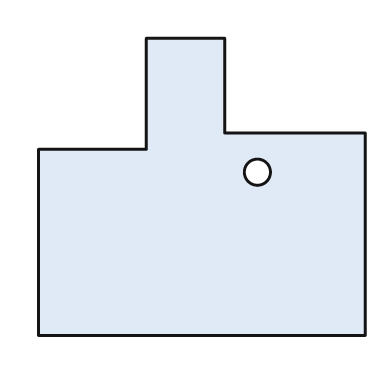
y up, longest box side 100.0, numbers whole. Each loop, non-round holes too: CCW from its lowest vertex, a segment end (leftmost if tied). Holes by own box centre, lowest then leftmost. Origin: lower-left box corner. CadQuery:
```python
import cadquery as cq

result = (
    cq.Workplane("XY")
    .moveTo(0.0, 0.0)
    .lineTo(100.0, 0.0)
    .lineTo(100.0, 62.0)
    .lineTo(57.0, 62.0)
    .lineTo(57.0, 91.0)
    .lineTo(33.0, 91.0)
    .lineTo(33.0, 57.0)
    .lineTo(0.0, 57.0)
    .close()
    .moveTo(67.0, 50.0)
    .circle(4.0)
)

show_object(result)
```